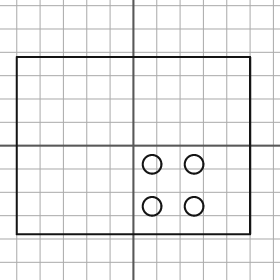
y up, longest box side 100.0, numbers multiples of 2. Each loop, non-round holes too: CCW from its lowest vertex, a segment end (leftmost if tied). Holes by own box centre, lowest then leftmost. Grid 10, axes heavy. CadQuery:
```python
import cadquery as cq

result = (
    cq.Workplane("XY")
    .moveTo(-50.0, -38.0)
    .lineTo(50.0, -38.0)
    .lineTo(50.0, 38.0)
    .lineTo(-50.0, 38.0)
    .close()
    .moveTo(8.0, -26.0)
    .circle(4.0)
    .moveTo(26.0, -26.0)
    .circle(4.0)
    .moveTo(8.0, -8.0)
    .circle(4.0)
    .moveTo(26.0, -8.0)
    .circle(4.0)
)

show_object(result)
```